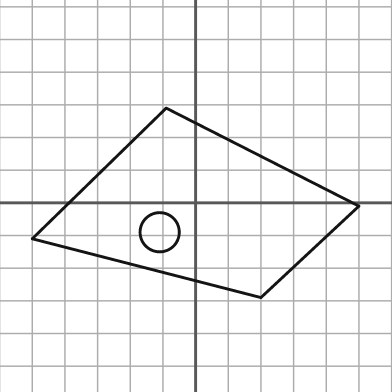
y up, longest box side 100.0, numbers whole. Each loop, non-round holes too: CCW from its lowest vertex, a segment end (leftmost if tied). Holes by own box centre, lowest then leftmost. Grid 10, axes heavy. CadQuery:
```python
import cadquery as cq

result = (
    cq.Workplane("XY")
    .moveTo(20.0, -29.0)
    .lineTo(50.0, -1.0)
    .lineTo(-9.0, 29.0)
    .lineTo(-50.0, -11.0)
    .close()
    .moveTo(-11.0, -9.0)
    .circle(6.0)
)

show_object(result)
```